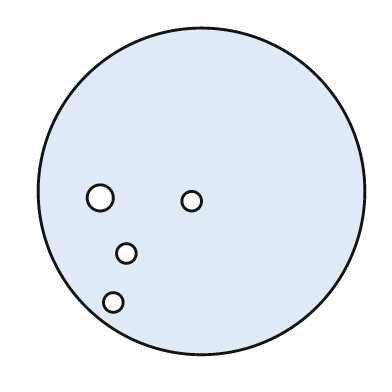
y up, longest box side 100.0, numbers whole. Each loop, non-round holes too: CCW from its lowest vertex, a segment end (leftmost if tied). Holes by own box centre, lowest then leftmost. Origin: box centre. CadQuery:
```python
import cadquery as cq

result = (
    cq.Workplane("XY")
    .moveTo(0.0, 0.0)
    .circle(50.0)
    .moveTo(-27.0, -34.0)
    .circle(3.0)
    .moveTo(-23.0, -19.0)
    .circle(3.0)
    .moveTo(-3.0, -3.0)
    .circle(3.0)
    .moveTo(-31.0, -2.0)
    .circle(4.0)
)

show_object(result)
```